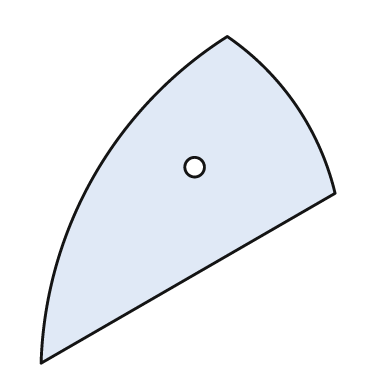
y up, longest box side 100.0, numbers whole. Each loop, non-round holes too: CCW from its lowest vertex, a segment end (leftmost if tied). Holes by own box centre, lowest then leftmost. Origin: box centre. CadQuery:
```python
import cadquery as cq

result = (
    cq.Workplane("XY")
    .moveTo(-45.0, -50.0)
    .lineTo(45.0, 2.0)
    .threePointArc((33.0, 29.0), (12.0, 50.0))
    .threePointArc((-29.0, 7.0), (-45.0, -50.0))
    .close()
    .moveTo(2.0, 10.0)
    .circle(3.0)
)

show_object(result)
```